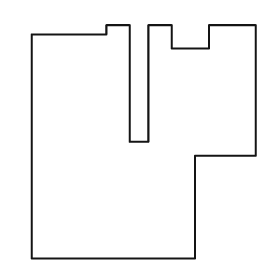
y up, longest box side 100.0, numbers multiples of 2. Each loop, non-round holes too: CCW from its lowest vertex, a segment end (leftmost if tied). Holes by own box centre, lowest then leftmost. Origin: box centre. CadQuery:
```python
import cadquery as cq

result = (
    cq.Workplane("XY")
    .moveTo(-48.0, -50.0)
    .lineTo(22.0, -50.0)
    .lineTo(22.0, -6.0)
    .lineTo(48.0, -6.0)
    .lineTo(48.0, 50.0)
    .lineTo(28.0, 50.0)
    .lineTo(28.0, 40.0)
    .lineTo(12.0, 40.0)
    .lineTo(12.0, 50.0)
    .lineTo(2.0, 50.0)
    .lineTo(2.0, 0.0)
    .lineTo(-6.0, 0.0)
    .lineTo(-6.0, 50.0)
    .lineTo(-16.0, 50.0)
    .lineTo(-16.0, 46.0)
    .lineTo(-48.0, 46.0)
    .close()
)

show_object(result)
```